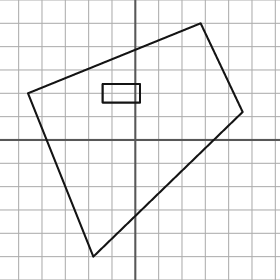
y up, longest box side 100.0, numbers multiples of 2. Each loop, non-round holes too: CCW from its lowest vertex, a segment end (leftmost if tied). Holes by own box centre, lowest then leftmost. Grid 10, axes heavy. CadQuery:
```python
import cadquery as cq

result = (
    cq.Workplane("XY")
    .moveTo(-18.0, -50.0)
    .lineTo(46.0, 12.0)
    .lineTo(28.0, 50.0)
    .lineTo(-46.0, 20.0)
    .close()
    .moveTo(-14.0, 16.0)
    .lineTo(2.0, 16.0)
    .lineTo(2.0, 24.0)
    .lineTo(-14.0, 24.0)
    .close()
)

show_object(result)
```